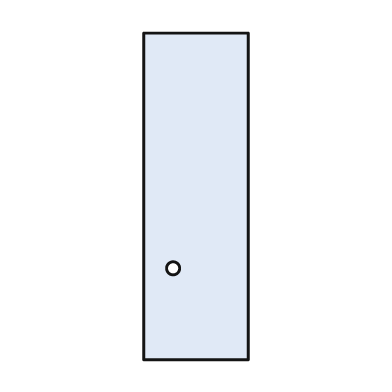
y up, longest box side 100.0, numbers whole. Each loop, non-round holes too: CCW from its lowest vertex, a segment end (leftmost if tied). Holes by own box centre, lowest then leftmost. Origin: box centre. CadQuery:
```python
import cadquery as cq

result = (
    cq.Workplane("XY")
    .moveTo(-16.0, -50.0)
    .lineTo(16.0, -50.0)
    .lineTo(16.0, 50.0)
    .lineTo(-16.0, 50.0)
    .close()
    .moveTo(-7.0, -22.0)
    .circle(2.0)
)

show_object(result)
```